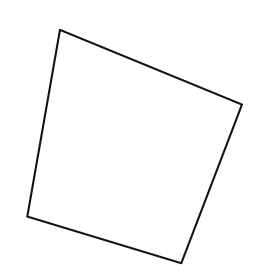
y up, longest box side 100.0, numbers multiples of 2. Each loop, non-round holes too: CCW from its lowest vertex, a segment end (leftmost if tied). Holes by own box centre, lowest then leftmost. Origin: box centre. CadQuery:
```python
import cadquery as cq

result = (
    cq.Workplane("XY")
    .moveTo(20.0, -50.0)
    .lineTo(46.0, 18.0)
    .lineTo(-32.0, 50.0)
    .lineTo(-46.0, -30.0)
    .close()
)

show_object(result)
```